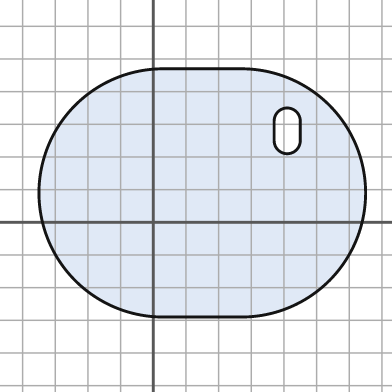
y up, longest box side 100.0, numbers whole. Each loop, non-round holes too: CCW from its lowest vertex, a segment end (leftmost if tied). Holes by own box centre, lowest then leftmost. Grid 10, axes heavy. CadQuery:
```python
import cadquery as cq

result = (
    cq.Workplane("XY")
    .moveTo(3.0, -29.0)
    .lineTo(27.0, -29.0)
    .threePointArc((65.0, 9.0), (27.0, 47.0))
    .lineTo(3.0, 47.0)
    .threePointArc((-35.0, 9.0), (3.0, -29.0))
    .close()
    .moveTo(37.0, 25.0)
    .threePointArc((41.0, 21.0), (45.0, 25.0))
    .lineTo(45.0, 31.0)
    .threePointArc((41.0, 35.0), (37.0, 31.0))
    .close()
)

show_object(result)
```